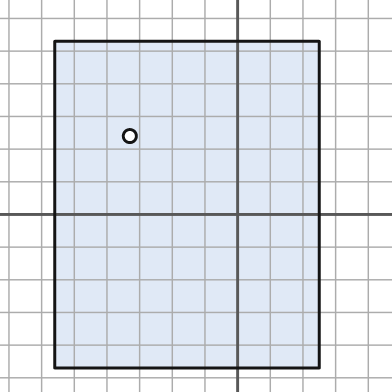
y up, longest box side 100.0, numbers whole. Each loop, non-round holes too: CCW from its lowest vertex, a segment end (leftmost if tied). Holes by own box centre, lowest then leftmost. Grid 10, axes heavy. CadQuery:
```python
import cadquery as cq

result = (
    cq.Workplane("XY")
    .moveTo(-56.0, -47.0)
    .lineTo(25.0, -47.0)
    .lineTo(25.0, 53.0)
    .lineTo(-56.0, 53.0)
    .close()
    .moveTo(-33.0, 24.0)
    .circle(2.0)
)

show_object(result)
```